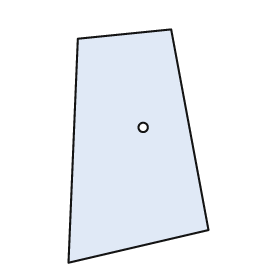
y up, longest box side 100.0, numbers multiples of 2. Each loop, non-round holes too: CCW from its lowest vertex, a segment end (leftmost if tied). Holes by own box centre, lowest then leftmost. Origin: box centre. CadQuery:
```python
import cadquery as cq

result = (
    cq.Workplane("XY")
    .moveTo(-30.0, -50.0)
    .lineTo(30.0, -36.0)
    .lineTo(14.0, 50.0)
    .lineTo(-26.0, 46.0)
    .close()
    .moveTo(2.0, 8.0)
    .circle(2.0)
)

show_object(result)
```